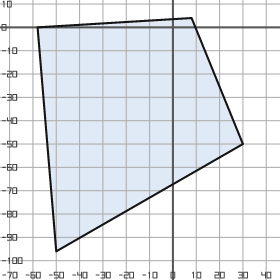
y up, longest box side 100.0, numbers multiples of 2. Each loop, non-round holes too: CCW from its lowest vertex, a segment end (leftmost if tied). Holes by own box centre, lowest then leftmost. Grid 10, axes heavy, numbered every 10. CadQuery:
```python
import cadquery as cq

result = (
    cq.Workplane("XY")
    .moveTo(-50.0, -96.0)
    .lineTo(30.0, -50.0)
    .lineTo(8.0, 4.0)
    .lineTo(-58.0, 0.0)
    .close()
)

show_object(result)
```